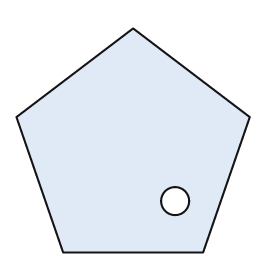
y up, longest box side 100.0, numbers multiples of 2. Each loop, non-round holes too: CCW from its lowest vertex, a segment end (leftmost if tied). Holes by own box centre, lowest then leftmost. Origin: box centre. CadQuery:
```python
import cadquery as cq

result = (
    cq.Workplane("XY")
    .moveTo(-30.0, -48.0)
    .lineTo(30.0, -48.0)
    .lineTo(50.0, 10.0)
    .lineTo(0.0, 48.0)
    .lineTo(-50.0, 10.0)
    .close()
    .moveTo(18.0, -26.0)
    .circle(6.0)
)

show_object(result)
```